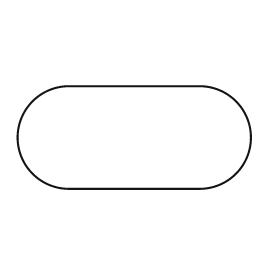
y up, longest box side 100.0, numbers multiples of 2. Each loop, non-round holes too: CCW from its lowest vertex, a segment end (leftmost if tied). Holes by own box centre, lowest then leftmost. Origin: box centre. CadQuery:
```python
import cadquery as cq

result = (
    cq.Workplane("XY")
    .moveTo(-28.0, -22.0)
    .lineTo(28.0, -22.0)
    .threePointArc((50.0, 0.0), (28.0, 22.0))
    .lineTo(-28.0, 22.0)
    .threePointArc((-50.0, 0.0), (-28.0, -22.0))
    .close()
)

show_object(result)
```